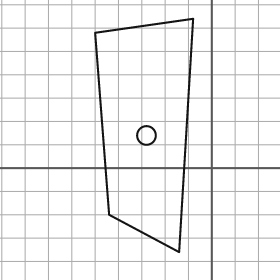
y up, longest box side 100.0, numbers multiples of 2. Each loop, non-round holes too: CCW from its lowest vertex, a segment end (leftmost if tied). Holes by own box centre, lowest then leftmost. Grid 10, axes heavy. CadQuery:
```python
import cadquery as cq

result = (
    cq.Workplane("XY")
    .moveTo(-14.0, -36.0)
    .lineTo(-8.0, 64.0)
    .lineTo(-50.0, 58.0)
    .lineTo(-44.0, -20.0)
    .close()
    .moveTo(-28.0, 14.0)
    .circle(4.0)
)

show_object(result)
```